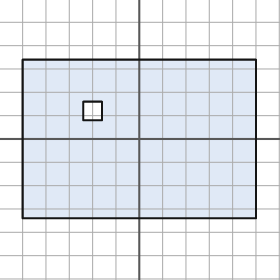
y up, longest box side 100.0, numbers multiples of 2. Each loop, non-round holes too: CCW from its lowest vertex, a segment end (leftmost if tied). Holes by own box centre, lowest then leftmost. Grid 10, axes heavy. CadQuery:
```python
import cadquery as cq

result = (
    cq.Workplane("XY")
    .moveTo(-50.0, -34.0)
    .lineTo(50.0, -34.0)
    .lineTo(50.0, 34.0)
    .lineTo(-50.0, 34.0)
    .close()
    .moveTo(-24.0, 8.0)
    .lineTo(-16.0, 8.0)
    .lineTo(-16.0, 16.0)
    .lineTo(-24.0, 16.0)
    .close()
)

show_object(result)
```